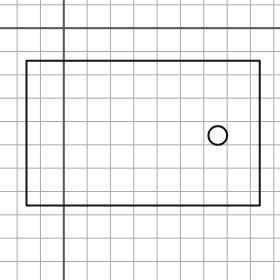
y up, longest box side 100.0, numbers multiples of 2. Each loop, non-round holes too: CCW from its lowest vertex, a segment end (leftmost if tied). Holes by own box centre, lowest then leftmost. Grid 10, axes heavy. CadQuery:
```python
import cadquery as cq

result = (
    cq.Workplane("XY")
    .moveTo(-16.0, -76.0)
    .lineTo(84.0, -76.0)
    .lineTo(84.0, -14.0)
    .lineTo(-16.0, -14.0)
    .close()
    .moveTo(66.0, -46.0)
    .circle(4.0)
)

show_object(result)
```